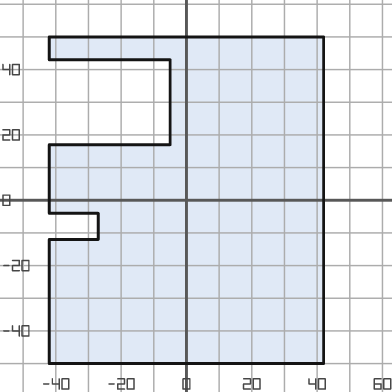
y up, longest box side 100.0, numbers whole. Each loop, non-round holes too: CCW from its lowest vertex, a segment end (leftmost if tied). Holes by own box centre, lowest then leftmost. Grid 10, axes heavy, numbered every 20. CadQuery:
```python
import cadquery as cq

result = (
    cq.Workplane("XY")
    .moveTo(-42.0, -50.0)
    .lineTo(42.0, -50.0)
    .lineTo(42.0, 50.0)
    .lineTo(-42.0, 50.0)
    .lineTo(-42.0, 43.0)
    .lineTo(-5.0, 43.0)
    .lineTo(-5.0, 17.0)
    .lineTo(-42.0, 17.0)
    .lineTo(-42.0, -4.0)
    .lineTo(-27.0, -4.0)
    .lineTo(-27.0, -12.0)
    .lineTo(-42.0, -12.0)
    .close()
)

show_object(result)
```